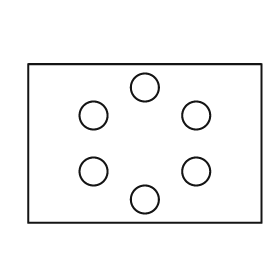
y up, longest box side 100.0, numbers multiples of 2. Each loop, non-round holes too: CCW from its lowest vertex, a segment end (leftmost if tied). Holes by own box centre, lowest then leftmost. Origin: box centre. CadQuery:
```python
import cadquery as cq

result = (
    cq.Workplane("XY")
    .moveTo(-50.0, -34.0)
    .lineTo(50.0, -34.0)
    .lineTo(50.0, 34.0)
    .lineTo(-50.0, 34.0)
    .close()
    .moveTo(0.0, -24.0)
    .circle(6.0)
    .moveTo(-22.0, -12.0)
    .circle(6.0)
    .moveTo(22.0, -12.0)
    .circle(6.0)
    .moveTo(-22.0, 12.0)
    .circle(6.0)
    .moveTo(22.0, 12.0)
    .circle(6.0)
    .moveTo(0.0, 24.0)
    .circle(6.0)
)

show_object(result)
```